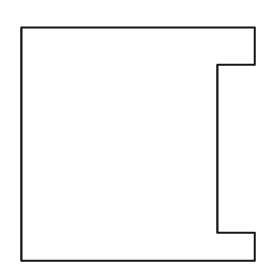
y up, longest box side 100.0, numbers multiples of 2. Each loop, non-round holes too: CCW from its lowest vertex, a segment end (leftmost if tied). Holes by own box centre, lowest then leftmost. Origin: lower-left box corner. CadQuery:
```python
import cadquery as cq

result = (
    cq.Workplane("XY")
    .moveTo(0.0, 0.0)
    .lineTo(100.0, 0.0)
    .lineTo(100.0, 12.0)
    .lineTo(84.0, 12.0)
    .lineTo(84.0, 84.0)
    .lineTo(100.0, 84.0)
    .lineTo(100.0, 100.0)
    .lineTo(0.0, 100.0)
    .close()
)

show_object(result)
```